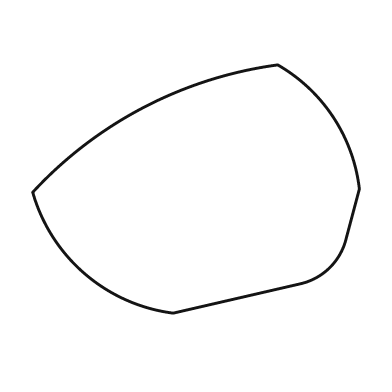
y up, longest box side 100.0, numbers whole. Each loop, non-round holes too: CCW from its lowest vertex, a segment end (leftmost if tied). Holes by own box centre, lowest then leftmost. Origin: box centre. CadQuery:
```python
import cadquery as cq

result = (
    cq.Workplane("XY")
    .moveTo(-7.0, -38.0)
    .lineTo(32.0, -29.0)
    .threePointArc((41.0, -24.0), (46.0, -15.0))
    .lineTo(50.0, 0.0)
    .threePointArc((42.0, 22.0), (25.0, 38.0))
    .threePointArc((-16.0, 25.0), (-50.0, -1.0))
    .threePointArc((-34.0, -26.0), (-7.0, -38.0))
    .close()
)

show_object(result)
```